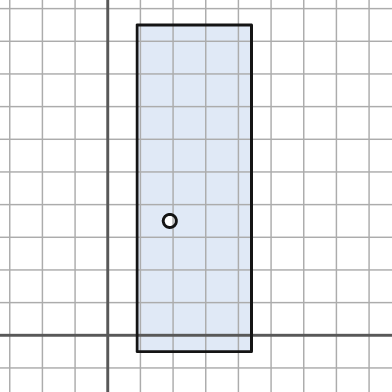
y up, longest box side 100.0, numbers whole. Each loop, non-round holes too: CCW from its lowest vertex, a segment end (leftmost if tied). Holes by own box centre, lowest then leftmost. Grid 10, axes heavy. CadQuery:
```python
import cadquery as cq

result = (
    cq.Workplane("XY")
    .moveTo(9.0, -5.0)
    .lineTo(44.0, -5.0)
    .lineTo(44.0, 95.0)
    .lineTo(9.0, 95.0)
    .close()
    .moveTo(19.0, 35.0)
    .circle(2.0)
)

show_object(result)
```